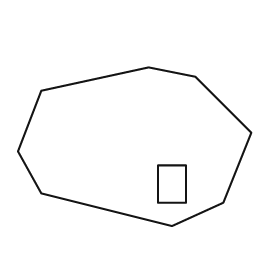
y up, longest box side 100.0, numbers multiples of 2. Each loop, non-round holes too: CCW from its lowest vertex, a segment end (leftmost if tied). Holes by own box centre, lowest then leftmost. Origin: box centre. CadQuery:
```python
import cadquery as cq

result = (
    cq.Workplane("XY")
    .moveTo(16.0, -34.0)
    .lineTo(38.0, -24.0)
    .lineTo(50.0, 6.0)
    .lineTo(26.0, 30.0)
    .lineTo(6.0, 34.0)
    .lineTo(-40.0, 24.0)
    .lineTo(-50.0, -2.0)
    .lineTo(-40.0, -20.0)
    .close()
    .moveTo(10.0, -24.0)
    .lineTo(22.0, -24.0)
    .lineTo(22.0, -8.0)
    .lineTo(10.0, -8.0)
    .close()
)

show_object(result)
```